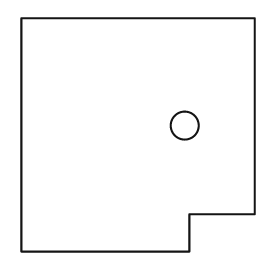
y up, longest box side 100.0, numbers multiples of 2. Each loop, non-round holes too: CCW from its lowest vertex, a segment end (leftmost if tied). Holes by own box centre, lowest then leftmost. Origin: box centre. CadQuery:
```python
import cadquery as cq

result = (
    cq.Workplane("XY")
    .moveTo(-50.0, -50.0)
    .lineTo(22.0, -50.0)
    .lineTo(22.0, -34.0)
    .lineTo(50.0, -34.0)
    .lineTo(50.0, 50.0)
    .lineTo(-50.0, 50.0)
    .close()
    .moveTo(20.0, 4.0)
    .circle(6.0)
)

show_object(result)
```